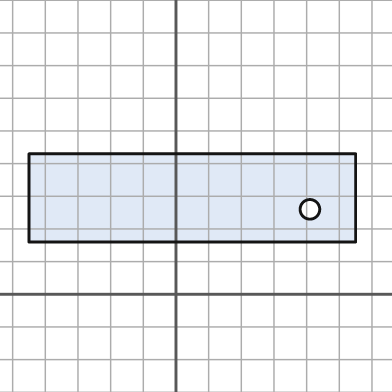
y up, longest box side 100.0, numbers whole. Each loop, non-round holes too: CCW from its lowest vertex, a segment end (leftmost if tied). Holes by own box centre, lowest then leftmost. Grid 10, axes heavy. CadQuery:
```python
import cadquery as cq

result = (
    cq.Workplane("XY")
    .moveTo(-45.0, 16.0)
    .lineTo(55.0, 16.0)
    .lineTo(55.0, 43.0)
    .lineTo(-45.0, 43.0)
    .close()
    .moveTo(41.0, 26.0)
    .circle(3.0)
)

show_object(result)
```